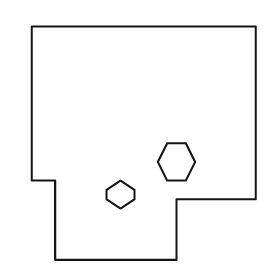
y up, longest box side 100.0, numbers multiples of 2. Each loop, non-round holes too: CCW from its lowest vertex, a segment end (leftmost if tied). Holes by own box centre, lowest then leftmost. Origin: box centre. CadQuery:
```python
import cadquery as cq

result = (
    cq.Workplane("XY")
    .moveTo(-38.0, -50.0)
    .lineTo(14.0, -50.0)
    .lineTo(14.0, -24.0)
    .lineTo(48.0, -24.0)
    .lineTo(48.0, 50.0)
    .lineTo(-48.0, 50.0)
    .lineTo(-48.0, -16.0)
    .lineTo(-38.0, -16.0)
    .close()
    .moveTo(-10.0, -28.0)
    .lineTo(-4.0, -24.0)
    .lineTo(-4.0, -20.0)
    .lineTo(-10.0, -16.0)
    .lineTo(-16.0, -20.0)
    .lineTo(-16.0, -24.0)
    .close()
    .moveTo(10.0, -16.0)
    .lineTo(18.0, -16.0)
    .lineTo(22.0, -8.0)
    .lineTo(18.0, 0.0)
    .lineTo(10.0, 0.0)
    .lineTo(6.0, -8.0)
    .close()
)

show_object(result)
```